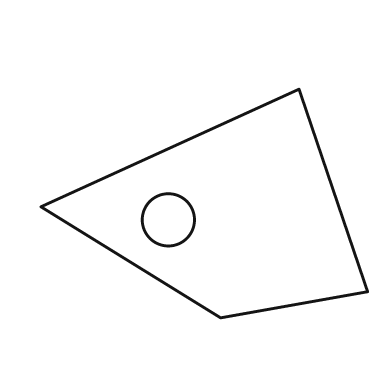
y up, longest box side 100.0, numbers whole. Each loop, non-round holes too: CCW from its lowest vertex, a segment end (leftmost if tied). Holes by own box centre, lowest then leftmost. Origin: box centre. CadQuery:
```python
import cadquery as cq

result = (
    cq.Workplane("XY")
    .moveTo(5.0, -35.0)
    .lineTo(50.0, -27.0)
    .lineTo(29.0, 35.0)
    .lineTo(-50.0, -1.0)
    .close()
    .moveTo(-11.0, -5.0)
    .circle(8.0)
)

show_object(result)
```